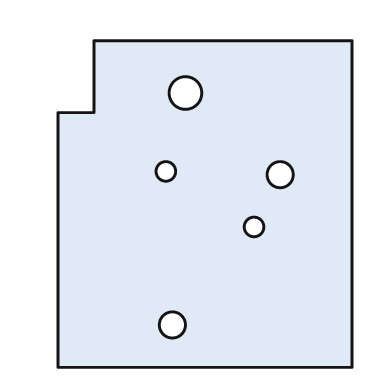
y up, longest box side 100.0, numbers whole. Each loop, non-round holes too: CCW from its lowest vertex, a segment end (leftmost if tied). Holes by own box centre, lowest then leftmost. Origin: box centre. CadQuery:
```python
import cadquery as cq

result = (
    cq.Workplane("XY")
    .moveTo(-45.0, -50.0)
    .lineTo(45.0, -50.0)
    .lineTo(45.0, 50.0)
    .lineTo(-34.0, 50.0)
    .lineTo(-34.0, 28.0)
    .lineTo(-45.0, 28.0)
    .close()
    .moveTo(-10.0, -37.0)
    .circle(4.0)
    .moveTo(15.0, -7.0)
    .circle(3.0)
    .moveTo(23.0, 9.0)
    .circle(4.0)
    .moveTo(-12.0, 10.0)
    .circle(3.0)
    .moveTo(-6.0, 34.0)
    .circle(5.0)
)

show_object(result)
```